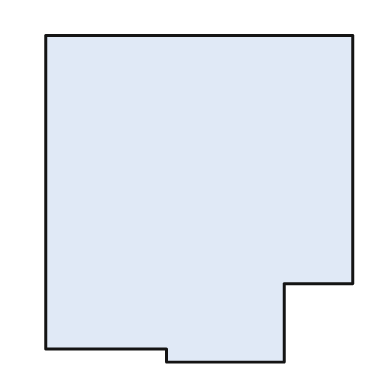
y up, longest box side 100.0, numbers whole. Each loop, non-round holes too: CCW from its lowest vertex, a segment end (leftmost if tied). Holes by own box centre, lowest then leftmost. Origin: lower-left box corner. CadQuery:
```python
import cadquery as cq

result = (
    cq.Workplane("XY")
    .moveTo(37.0, 0.0)
    .lineTo(73.0, 0.0)
    .lineTo(73.0, 24.0)
    .lineTo(94.0, 24.0)
    .lineTo(94.0, 100.0)
    .lineTo(0.0, 100.0)
    .lineTo(0.0, 4.0)
    .lineTo(37.0, 4.0)
    .close()
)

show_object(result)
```